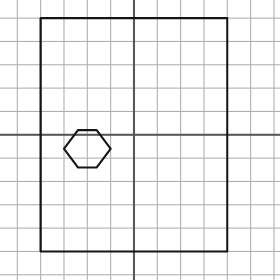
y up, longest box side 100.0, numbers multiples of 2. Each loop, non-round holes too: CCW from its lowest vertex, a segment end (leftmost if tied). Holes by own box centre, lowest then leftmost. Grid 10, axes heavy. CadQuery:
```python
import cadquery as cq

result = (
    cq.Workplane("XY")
    .moveTo(-40.0, -50.0)
    .lineTo(40.0, -50.0)
    .lineTo(40.0, 50.0)
    .lineTo(-40.0, 50.0)
    .close()
    .moveTo(-24.0, -14.0)
    .lineTo(-16.0, -14.0)
    .lineTo(-10.0, -6.0)
    .lineTo(-16.0, 2.0)
    .lineTo(-24.0, 2.0)
    .lineTo(-30.0, -6.0)
    .close()
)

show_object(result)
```